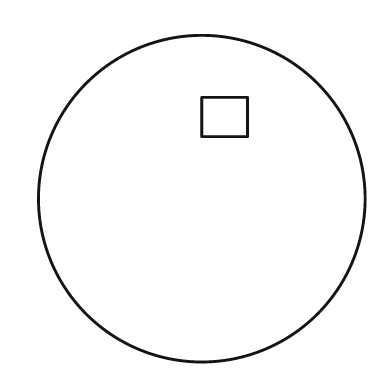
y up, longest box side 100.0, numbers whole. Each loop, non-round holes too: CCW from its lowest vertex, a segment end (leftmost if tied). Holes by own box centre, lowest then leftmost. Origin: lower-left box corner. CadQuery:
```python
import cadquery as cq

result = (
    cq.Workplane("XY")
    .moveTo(50.0, 50.0)
    .circle(50.0)
    .moveTo(50.0, 69.0)
    .lineTo(64.0, 69.0)
    .lineTo(64.0, 81.0)
    .lineTo(50.0, 81.0)
    .close()
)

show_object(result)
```